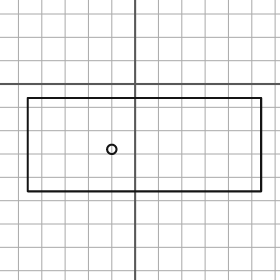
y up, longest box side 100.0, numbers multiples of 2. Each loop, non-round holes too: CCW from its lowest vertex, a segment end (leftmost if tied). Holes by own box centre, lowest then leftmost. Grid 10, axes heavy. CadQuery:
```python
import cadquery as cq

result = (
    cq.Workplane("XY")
    .moveTo(-46.0, -46.0)
    .lineTo(54.0, -46.0)
    .lineTo(54.0, -6.0)
    .lineTo(-46.0, -6.0)
    .close()
    .moveTo(-10.0, -28.0)
    .circle(2.0)
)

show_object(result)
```